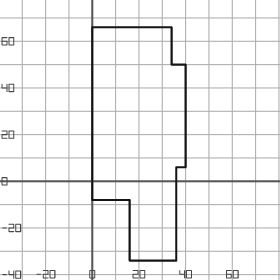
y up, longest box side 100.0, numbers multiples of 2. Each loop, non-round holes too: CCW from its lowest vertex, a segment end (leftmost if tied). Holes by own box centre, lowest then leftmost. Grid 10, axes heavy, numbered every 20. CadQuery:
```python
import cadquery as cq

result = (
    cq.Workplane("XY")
    .moveTo(16.0, -34.0)
    .lineTo(36.0, -34.0)
    .lineTo(36.0, 6.0)
    .lineTo(40.0, 6.0)
    .lineTo(40.0, 50.0)
    .lineTo(34.0, 50.0)
    .lineTo(34.0, 66.0)
    .lineTo(0.0, 66.0)
    .lineTo(0.0, -8.0)
    .lineTo(16.0, -8.0)
    .close()
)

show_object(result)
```